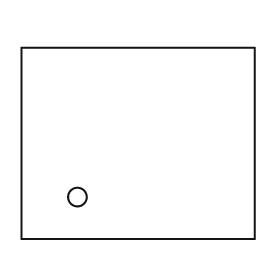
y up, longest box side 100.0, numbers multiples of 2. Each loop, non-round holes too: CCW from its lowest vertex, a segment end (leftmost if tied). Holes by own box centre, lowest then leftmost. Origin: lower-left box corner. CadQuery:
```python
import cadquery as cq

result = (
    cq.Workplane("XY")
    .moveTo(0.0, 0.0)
    .lineTo(100.0, 0.0)
    .lineTo(100.0, 82.0)
    .lineTo(0.0, 82.0)
    .close()
    .moveTo(24.0, 18.0)
    .circle(4.0)
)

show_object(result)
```